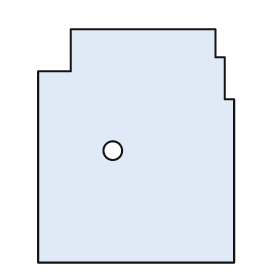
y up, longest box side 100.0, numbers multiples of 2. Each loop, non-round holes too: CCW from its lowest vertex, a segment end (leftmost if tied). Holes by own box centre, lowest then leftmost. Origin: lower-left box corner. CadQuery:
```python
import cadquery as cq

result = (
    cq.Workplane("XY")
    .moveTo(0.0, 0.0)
    .lineTo(84.0, 0.0)
    .lineTo(84.0, 70.0)
    .lineTo(80.0, 70.0)
    .lineTo(80.0, 88.0)
    .lineTo(76.0, 88.0)
    .lineTo(76.0, 100.0)
    .lineTo(14.0, 100.0)
    .lineTo(14.0, 82.0)
    .lineTo(0.0, 82.0)
    .close()
    .moveTo(32.0, 48.0)
    .circle(4.0)
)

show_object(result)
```